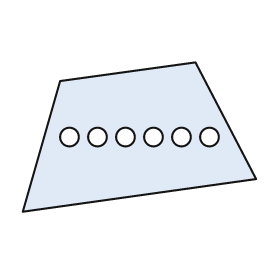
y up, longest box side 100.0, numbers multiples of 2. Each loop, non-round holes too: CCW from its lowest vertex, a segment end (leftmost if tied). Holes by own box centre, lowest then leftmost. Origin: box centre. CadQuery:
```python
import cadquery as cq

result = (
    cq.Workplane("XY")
    .moveTo(-50.0, -32.0)
    .lineTo(50.0, -18.0)
    .lineTo(24.0, 32.0)
    .lineTo(-34.0, 24.0)
    .close()
    .moveTo(-30.0, 0.0)
    .circle(4.0)
    .moveTo(-18.0, 0.0)
    .circle(4.0)
    .moveTo(-6.0, 0.0)
    .circle(4.0)
    .moveTo(6.0, 0.0)
    .circle(4.0)
    .moveTo(18.0, 0.0)
    .circle(4.0)
    .moveTo(30.0, 0.0)
    .circle(4.0)
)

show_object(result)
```